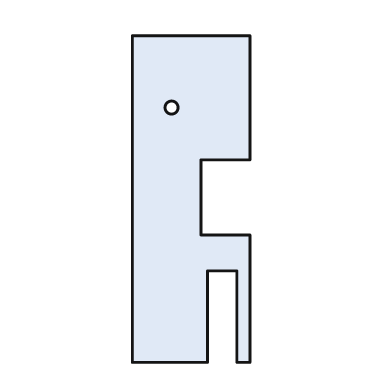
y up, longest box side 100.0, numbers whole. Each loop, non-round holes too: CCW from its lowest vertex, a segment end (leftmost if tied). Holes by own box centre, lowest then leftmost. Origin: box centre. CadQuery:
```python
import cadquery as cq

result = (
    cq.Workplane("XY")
    .moveTo(-18.0, -50.0)
    .lineTo(5.0, -50.0)
    .lineTo(5.0, -22.0)
    .lineTo(14.0, -22.0)
    .lineTo(14.0, -50.0)
    .lineTo(18.0, -50.0)
    .lineTo(18.0, -11.0)
    .lineTo(3.0, -11.0)
    .lineTo(3.0, 12.0)
    .lineTo(18.0, 12.0)
    .lineTo(18.0, 50.0)
    .lineTo(-18.0, 50.0)
    .close()
    .moveTo(-6.0, 28.0)
    .circle(2.0)
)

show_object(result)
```